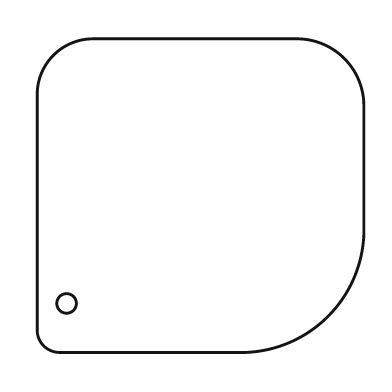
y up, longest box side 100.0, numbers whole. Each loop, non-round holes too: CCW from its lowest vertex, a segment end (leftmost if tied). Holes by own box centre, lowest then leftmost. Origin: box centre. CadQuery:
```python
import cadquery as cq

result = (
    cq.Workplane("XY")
    .moveTo(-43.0, -48.0)
    .lineTo(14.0, -48.0)
    .threePointArc((39.0, -37.0), (50.0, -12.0))
    .lineTo(50.0, 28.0)
    .threePointArc((44.0, 42.0), (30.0, 48.0))
    .lineTo(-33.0, 48.0)
    .threePointArc((-45.0, 43.0), (-50.0, 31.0))
    .lineTo(-50.0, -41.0)
    .threePointArc((-48.0, -46.0), (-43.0, -48.0))
    .close()
    .moveTo(-41.0, -33.0)
    .circle(3.0)
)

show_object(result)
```